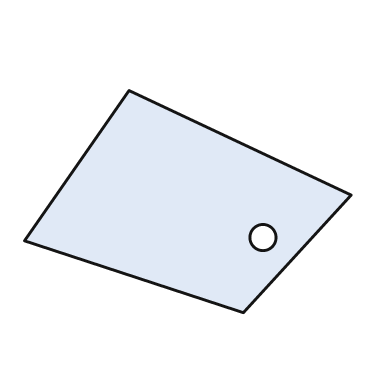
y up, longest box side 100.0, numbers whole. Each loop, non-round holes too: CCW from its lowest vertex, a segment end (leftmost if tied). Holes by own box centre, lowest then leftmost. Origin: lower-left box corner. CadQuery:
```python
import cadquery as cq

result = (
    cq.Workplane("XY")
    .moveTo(67.0, 0.0)
    .lineTo(100.0, 36.0)
    .lineTo(32.0, 68.0)
    .lineTo(0.0, 22.0)
    .close()
    .moveTo(73.0, 23.0)
    .circle(4.0)
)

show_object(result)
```